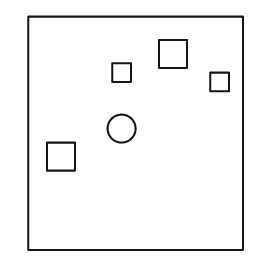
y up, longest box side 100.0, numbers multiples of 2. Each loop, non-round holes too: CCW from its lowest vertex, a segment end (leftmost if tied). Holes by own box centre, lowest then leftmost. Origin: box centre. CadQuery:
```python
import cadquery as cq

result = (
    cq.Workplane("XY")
    .moveTo(-46.0, -50.0)
    .lineTo(46.0, -50.0)
    .lineTo(46.0, 50.0)
    .lineTo(-46.0, 50.0)
    .close()
    .moveTo(-38.0, -16.0)
    .lineTo(-26.0, -16.0)
    .lineTo(-26.0, -4.0)
    .lineTo(-38.0, -4.0)
    .close()
    .moveTo(-6.0, 2.0)
    .circle(6.0)
    .moveTo(32.0, 18.0)
    .lineTo(40.0, 18.0)
    .lineTo(40.0, 26.0)
    .lineTo(32.0, 26.0)
    .close()
    .moveTo(-10.0, 22.0)
    .lineTo(-2.0, 22.0)
    .lineTo(-2.0, 30.0)
    .lineTo(-10.0, 30.0)
    .close()
    .moveTo(10.0, 28.0)
    .lineTo(22.0, 28.0)
    .lineTo(22.0, 40.0)
    .lineTo(10.0, 40.0)
    .close()
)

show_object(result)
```